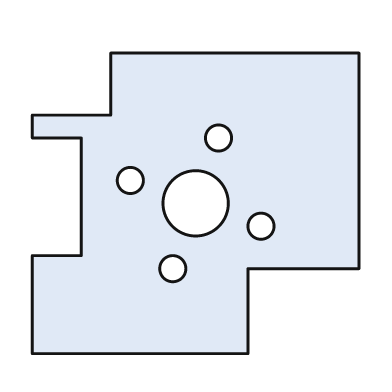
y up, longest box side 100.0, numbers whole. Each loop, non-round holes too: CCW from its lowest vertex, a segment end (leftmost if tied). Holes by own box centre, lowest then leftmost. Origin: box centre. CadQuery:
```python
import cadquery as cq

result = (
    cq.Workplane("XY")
    .moveTo(-50.0, -46.0)
    .lineTo(16.0, -46.0)
    .lineTo(16.0, -20.0)
    .lineTo(50.0, -20.0)
    .lineTo(50.0, 46.0)
    .lineTo(-26.0, 46.0)
    .lineTo(-26.0, 27.0)
    .lineTo(-50.0, 27.0)
    .lineTo(-50.0, 20.0)
    .lineTo(-35.0, 20.0)
    .lineTo(-35.0, -16.0)
    .lineTo(-50.0, -16.0)
    .close()
    .moveTo(-7.0, -20.0)
    .circle(4.0)
    .moveTo(20.0, -7.0)
    .circle(4.0)
    .moveTo(0.0, 0.0)
    .circle(10.0)
    .moveTo(-20.0, 7.0)
    .circle(4.0)
    .moveTo(7.0, 20.0)
    .circle(4.0)
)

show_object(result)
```